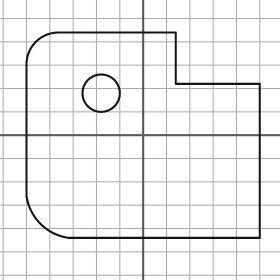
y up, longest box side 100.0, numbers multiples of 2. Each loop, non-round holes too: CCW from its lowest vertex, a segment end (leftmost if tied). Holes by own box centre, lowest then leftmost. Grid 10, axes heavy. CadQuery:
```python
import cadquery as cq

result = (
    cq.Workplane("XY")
    .moveTo(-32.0, -44.0)
    .lineTo(50.0, -44.0)
    .lineTo(50.0, 22.0)
    .lineTo(14.0, 22.0)
    .lineTo(14.0, 44.0)
    .lineTo(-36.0, 44.0)
    .threePointArc((-46.0, 40.0), (-50.0, 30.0))
    .lineTo(-50.0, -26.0)
    .threePointArc((-44.0, -38.0), (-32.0, -44.0))
    .close()
    .moveTo(-18.0, 18.0)
    .circle(8.0)
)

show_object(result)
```